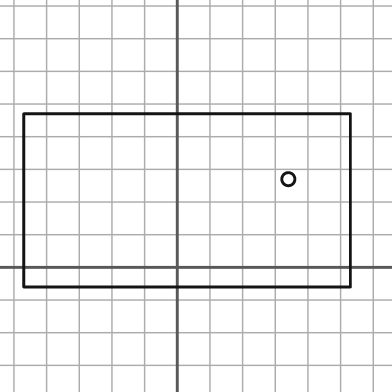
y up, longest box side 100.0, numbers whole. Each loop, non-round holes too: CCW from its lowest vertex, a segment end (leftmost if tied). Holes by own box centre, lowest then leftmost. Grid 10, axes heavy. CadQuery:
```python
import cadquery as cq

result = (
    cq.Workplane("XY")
    .moveTo(-47.0, -6.0)
    .lineTo(53.0, -6.0)
    .lineTo(53.0, 47.0)
    .lineTo(-47.0, 47.0)
    .close()
    .moveTo(34.0, 27.0)
    .circle(2.0)
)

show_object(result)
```